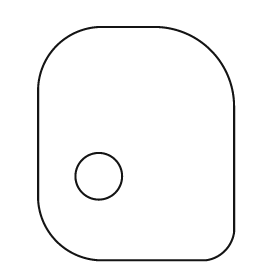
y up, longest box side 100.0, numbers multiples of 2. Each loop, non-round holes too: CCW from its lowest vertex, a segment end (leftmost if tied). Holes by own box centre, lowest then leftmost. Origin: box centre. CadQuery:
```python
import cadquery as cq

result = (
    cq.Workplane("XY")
    .moveTo(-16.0, -50.0)
    .lineTo(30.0, -50.0)
    .threePointArc((38.0, -46.0), (42.0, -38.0))
    .lineTo(42.0, 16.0)
    .threePointArc((32.0, 40.0), (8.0, 50.0))
    .lineTo(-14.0, 50.0)
    .threePointArc((-34.0, 42.0), (-42.0, 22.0))
    .lineTo(-42.0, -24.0)
    .threePointArc((-34.0, -42.0), (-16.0, -50.0))
    .close()
    .moveTo(-16.0, -14.0)
    .circle(10.0)
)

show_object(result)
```